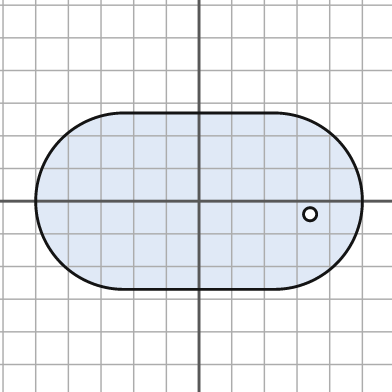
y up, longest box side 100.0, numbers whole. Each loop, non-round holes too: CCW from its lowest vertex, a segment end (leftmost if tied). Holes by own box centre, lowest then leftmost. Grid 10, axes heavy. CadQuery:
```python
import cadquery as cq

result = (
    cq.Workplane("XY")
    .moveTo(-23.0, -27.0)
    .lineTo(23.0, -27.0)
    .threePointArc((50.0, 0.0), (23.0, 27.0))
    .lineTo(-23.0, 27.0)
    .threePointArc((-50.0, 0.0), (-23.0, -27.0))
    .close()
    .moveTo(34.0, -4.0)
    .circle(2.0)
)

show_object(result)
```